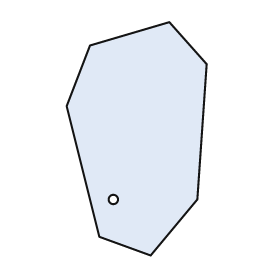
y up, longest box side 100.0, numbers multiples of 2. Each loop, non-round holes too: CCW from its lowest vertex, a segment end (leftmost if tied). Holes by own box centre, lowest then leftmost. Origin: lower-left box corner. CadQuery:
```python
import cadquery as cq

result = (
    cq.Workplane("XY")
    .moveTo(36.0, 0.0)
    .lineTo(56.0, 24.0)
    .lineTo(60.0, 82.0)
    .lineTo(44.0, 100.0)
    .lineTo(10.0, 90.0)
    .lineTo(0.0, 64.0)
    .lineTo(14.0, 8.0)
    .close()
    .moveTo(20.0, 24.0)
    .circle(2.0)
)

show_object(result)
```